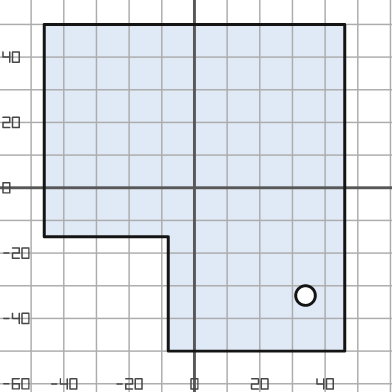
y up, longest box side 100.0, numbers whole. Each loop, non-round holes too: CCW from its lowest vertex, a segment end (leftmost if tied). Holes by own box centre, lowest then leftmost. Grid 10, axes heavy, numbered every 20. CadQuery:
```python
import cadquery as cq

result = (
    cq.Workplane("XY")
    .moveTo(-8.0, -50.0)
    .lineTo(46.0, -50.0)
    .lineTo(46.0, 50.0)
    .lineTo(-46.0, 50.0)
    .lineTo(-46.0, -15.0)
    .lineTo(-8.0, -15.0)
    .close()
    .moveTo(34.0, -33.0)
    .circle(3.0)
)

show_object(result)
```